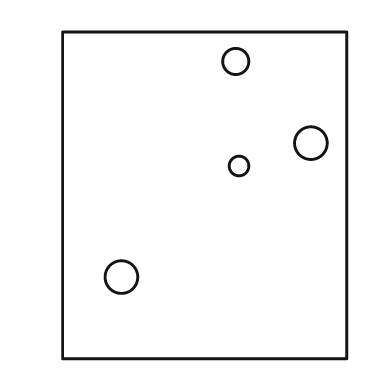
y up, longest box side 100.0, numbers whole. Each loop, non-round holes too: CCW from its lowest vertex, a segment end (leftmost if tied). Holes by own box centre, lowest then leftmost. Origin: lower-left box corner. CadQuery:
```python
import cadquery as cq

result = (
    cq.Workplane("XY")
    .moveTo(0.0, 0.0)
    .lineTo(87.0, 0.0)
    .lineTo(87.0, 100.0)
    .lineTo(0.0, 100.0)
    .close()
    .moveTo(18.0, 25.0)
    .circle(5.0)
    .moveTo(54.0, 59.0)
    .circle(3.0)
    .moveTo(76.0, 66.0)
    .circle(5.0)
    .moveTo(53.0, 91.0)
    .circle(4.0)
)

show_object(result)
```